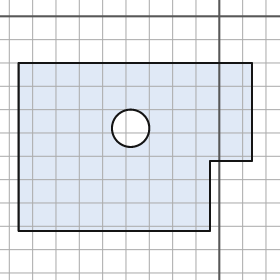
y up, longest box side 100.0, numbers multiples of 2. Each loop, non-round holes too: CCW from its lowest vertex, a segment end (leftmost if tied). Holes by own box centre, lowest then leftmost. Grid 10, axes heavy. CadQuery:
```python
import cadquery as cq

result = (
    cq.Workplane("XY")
    .moveTo(-86.0, -92.0)
    .lineTo(-4.0, -92.0)
    .lineTo(-4.0, -62.0)
    .lineTo(14.0, -62.0)
    .lineTo(14.0, -20.0)
    .lineTo(-86.0, -20.0)
    .close()
    .moveTo(-38.0, -48.0)
    .circle(8.0)
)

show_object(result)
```